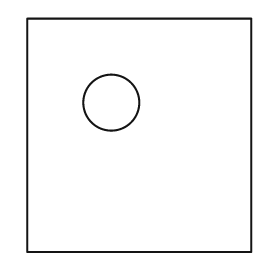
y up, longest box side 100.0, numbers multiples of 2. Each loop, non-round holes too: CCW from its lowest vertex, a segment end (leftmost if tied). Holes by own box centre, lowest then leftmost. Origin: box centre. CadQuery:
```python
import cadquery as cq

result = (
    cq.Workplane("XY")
    .moveTo(-48.0, -50.0)
    .lineTo(48.0, -50.0)
    .lineTo(48.0, 50.0)
    .lineTo(-48.0, 50.0)
    .close()
    .moveTo(-12.0, 14.0)
    .circle(12.0)
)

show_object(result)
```